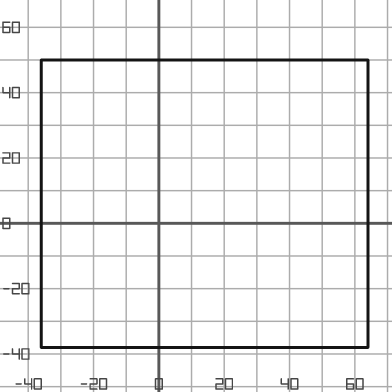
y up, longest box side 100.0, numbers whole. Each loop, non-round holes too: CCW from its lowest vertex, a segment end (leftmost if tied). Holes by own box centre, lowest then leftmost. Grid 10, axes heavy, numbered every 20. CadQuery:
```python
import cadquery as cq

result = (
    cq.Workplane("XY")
    .moveTo(-36.0, -38.0)
    .lineTo(64.0, -38.0)
    .lineTo(64.0, 50.0)
    .lineTo(-36.0, 50.0)
    .close()
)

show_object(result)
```